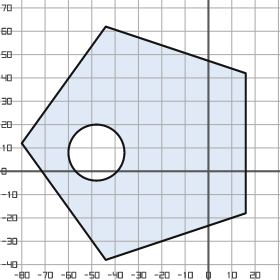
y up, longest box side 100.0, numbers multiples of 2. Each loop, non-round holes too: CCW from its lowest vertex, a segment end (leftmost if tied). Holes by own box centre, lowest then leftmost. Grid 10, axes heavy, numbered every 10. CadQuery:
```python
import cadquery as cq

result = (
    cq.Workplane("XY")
    .moveTo(-44.0, -38.0)
    .lineTo(16.0, -18.0)
    .lineTo(16.0, 42.0)
    .lineTo(-44.0, 62.0)
    .lineTo(-80.0, 12.0)
    .close()
    .moveTo(-48.0, 8.0)
    .circle(12.0)
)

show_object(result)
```